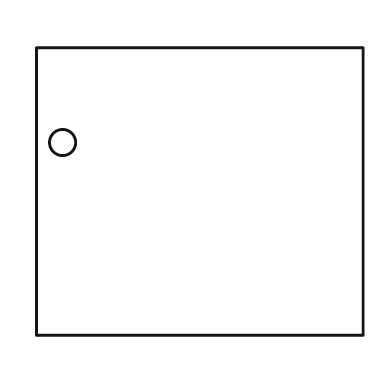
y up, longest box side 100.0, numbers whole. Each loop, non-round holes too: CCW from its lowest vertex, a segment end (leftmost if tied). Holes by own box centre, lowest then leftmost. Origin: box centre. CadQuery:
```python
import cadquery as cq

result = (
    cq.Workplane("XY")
    .moveTo(-50.0, -44.0)
    .lineTo(50.0, -44.0)
    .lineTo(50.0, 44.0)
    .lineTo(-50.0, 44.0)
    .close()
    .moveTo(-42.0, 15.0)
    .circle(4.0)
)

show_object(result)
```